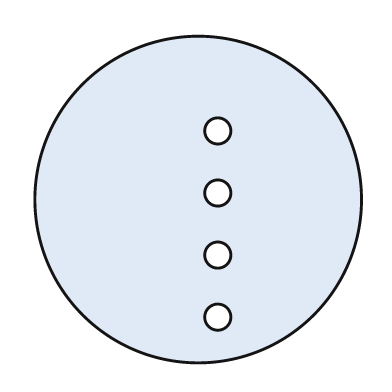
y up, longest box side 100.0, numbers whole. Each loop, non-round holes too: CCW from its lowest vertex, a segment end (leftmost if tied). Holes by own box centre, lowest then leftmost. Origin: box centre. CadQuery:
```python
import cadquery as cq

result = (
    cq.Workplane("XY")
    .moveTo(0.0, 0.0)
    .circle(50.0)
    .moveTo(6.0, -36.0)
    .circle(4.0)
    .moveTo(6.0, -17.0)
    .circle(4.0)
    .moveTo(6.0, 2.0)
    .circle(4.0)
    .moveTo(6.0, 21.0)
    .circle(4.0)
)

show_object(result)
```